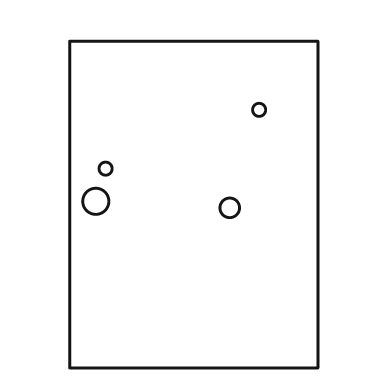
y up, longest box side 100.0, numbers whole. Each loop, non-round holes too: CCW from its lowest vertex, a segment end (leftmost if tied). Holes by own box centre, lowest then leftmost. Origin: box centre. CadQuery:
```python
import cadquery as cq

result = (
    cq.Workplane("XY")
    .moveTo(-38.0, -50.0)
    .lineTo(38.0, -50.0)
    .lineTo(38.0, 50.0)
    .lineTo(-38.0, 50.0)
    .close()
    .moveTo(11.0, -1.0)
    .circle(3.0)
    .moveTo(-30.0, 1.0)
    .circle(4.0)
    .moveTo(-27.0, 11.0)
    .circle(2.0)
    .moveTo(20.0, 29.0)
    .circle(2.0)
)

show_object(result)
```